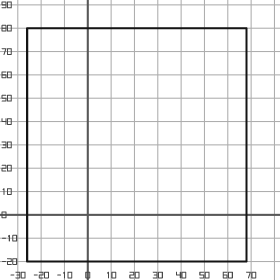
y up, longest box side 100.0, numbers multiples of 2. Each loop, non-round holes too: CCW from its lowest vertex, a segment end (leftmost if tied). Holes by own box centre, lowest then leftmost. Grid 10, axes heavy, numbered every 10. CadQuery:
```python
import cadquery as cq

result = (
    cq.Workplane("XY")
    .moveTo(-26.0, -20.0)
    .lineTo(68.0, -20.0)
    .lineTo(68.0, 80.0)
    .lineTo(-26.0, 80.0)
    .close()
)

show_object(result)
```